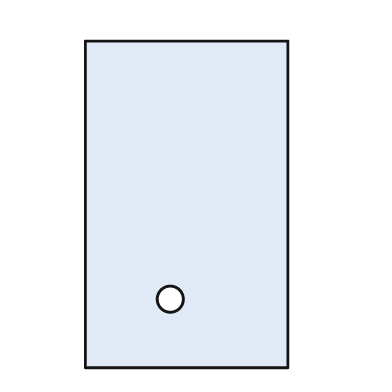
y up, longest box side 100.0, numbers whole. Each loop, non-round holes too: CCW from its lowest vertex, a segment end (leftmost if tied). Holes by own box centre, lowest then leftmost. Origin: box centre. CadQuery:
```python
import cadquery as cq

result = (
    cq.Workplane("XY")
    .moveTo(-31.0, -50.0)
    .lineTo(31.0, -50.0)
    .lineTo(31.0, 50.0)
    .lineTo(-31.0, 50.0)
    .close()
    .moveTo(-5.0, -29.0)
    .circle(4.0)
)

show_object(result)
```